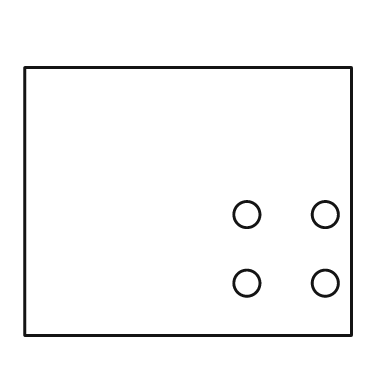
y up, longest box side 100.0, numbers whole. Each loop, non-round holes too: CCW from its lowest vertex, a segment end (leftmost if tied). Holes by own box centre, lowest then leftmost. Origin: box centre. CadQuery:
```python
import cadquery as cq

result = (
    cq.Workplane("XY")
    .moveTo(-50.0, -41.0)
    .lineTo(50.0, -41.0)
    .lineTo(50.0, 41.0)
    .lineTo(-50.0, 41.0)
    .close()
    .moveTo(18.0, -25.0)
    .circle(4.0)
    .moveTo(42.0, -25.0)
    .circle(4.0)
    .moveTo(18.0, -4.0)
    .circle(4.0)
    .moveTo(42.0, -4.0)
    .circle(4.0)
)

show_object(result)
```